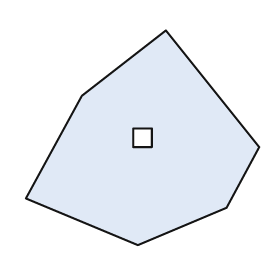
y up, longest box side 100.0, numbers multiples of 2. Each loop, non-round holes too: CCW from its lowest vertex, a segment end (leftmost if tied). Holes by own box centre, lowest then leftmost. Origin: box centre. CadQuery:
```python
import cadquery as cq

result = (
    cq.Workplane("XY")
    .moveTo(-2.0, -46.0)
    .lineTo(36.0, -30.0)
    .lineTo(50.0, -4.0)
    .lineTo(10.0, 46.0)
    .lineTo(-26.0, 18.0)
    .lineTo(-50.0, -26.0)
    .close()
    .moveTo(-4.0, -4.0)
    .lineTo(4.0, -4.0)
    .lineTo(4.0, 4.0)
    .lineTo(-4.0, 4.0)
    .close()
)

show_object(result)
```